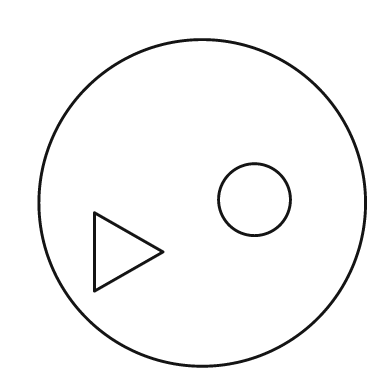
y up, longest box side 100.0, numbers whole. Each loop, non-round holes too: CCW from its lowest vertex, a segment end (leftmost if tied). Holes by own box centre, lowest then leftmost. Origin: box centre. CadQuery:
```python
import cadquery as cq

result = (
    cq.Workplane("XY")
    .moveTo(0.0, 0.0)
    .circle(50.0)
    .moveTo(-33.0, -27.0)
    .lineTo(-12.0, -15.0)
    .lineTo(-33.0, -3.0)
    .close()
    .moveTo(16.0, 1.0)
    .circle(11.0)
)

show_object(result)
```